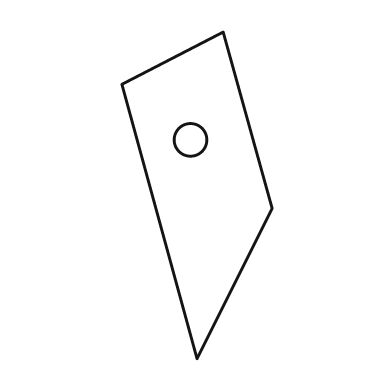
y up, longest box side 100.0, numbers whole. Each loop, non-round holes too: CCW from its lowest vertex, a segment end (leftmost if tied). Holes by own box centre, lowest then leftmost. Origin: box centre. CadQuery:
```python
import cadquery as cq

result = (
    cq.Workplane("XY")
    .moveTo(0.0, -50.0)
    .lineTo(23.0, -4.0)
    .lineTo(8.0, 50.0)
    .lineTo(-23.0, 34.0)
    .close()
    .moveTo(-2.0, 17.0)
    .circle(5.0)
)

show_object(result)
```